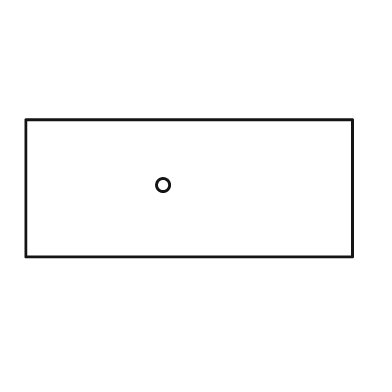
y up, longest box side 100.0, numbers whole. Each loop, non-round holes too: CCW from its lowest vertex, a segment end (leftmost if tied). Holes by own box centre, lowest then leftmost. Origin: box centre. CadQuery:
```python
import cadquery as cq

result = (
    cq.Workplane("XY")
    .moveTo(-50.0, -21.0)
    .lineTo(50.0, -21.0)
    .lineTo(50.0, 21.0)
    .lineTo(-50.0, 21.0)
    .close()
    .moveTo(-8.0, 1.0)
    .circle(2.0)
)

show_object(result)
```